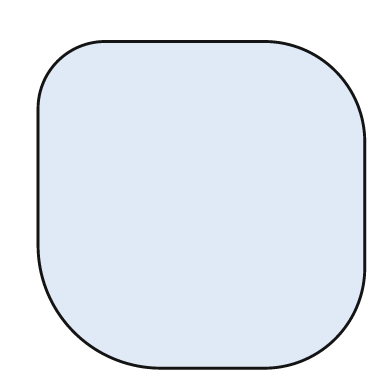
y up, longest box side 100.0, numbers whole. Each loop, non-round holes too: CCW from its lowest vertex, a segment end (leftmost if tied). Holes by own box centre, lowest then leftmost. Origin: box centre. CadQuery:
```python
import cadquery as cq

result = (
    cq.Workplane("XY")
    .moveTo(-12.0, -50.0)
    .lineTo(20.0, -50.0)
    .threePointArc((41.0, -41.0), (50.0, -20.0))
    .lineTo(50.0, 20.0)
    .threePointArc((41.0, 41.0), (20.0, 50.0))
    .lineTo(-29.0, 50.0)
    .threePointArc((-44.0, 44.0), (-50.0, 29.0))
    .lineTo(-50.0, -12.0)
    .threePointArc((-39.0, -39.0), (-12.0, -50.0))
    .close()
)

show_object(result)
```